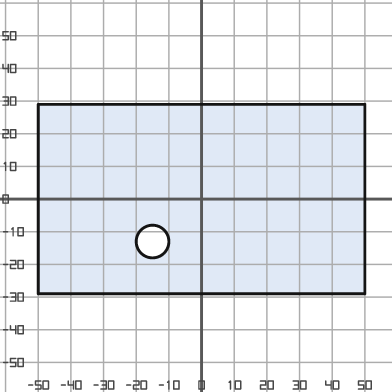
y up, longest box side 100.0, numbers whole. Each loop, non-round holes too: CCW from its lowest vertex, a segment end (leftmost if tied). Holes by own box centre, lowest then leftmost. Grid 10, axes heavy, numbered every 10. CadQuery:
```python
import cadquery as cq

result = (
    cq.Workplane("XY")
    .moveTo(-50.0, -29.0)
    .lineTo(50.0, -29.0)
    .lineTo(50.0, 29.0)
    .lineTo(-50.0, 29.0)
    .close()
    .moveTo(-15.0, -13.0)
    .circle(5.0)
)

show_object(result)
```